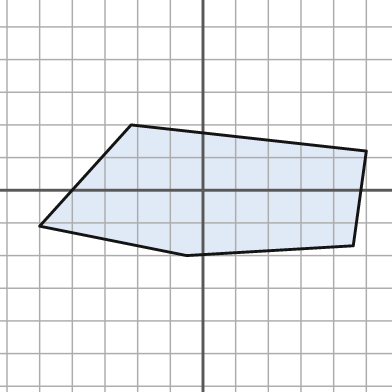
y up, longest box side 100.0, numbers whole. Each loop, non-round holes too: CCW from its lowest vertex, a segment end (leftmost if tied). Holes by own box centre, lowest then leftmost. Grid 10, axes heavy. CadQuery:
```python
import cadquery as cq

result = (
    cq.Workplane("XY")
    .moveTo(-5.0, -20.0)
    .lineTo(46.0, -17.0)
    .lineTo(50.0, 12.0)
    .lineTo(-22.0, 20.0)
    .lineTo(-50.0, -11.0)
    .close()
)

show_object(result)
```